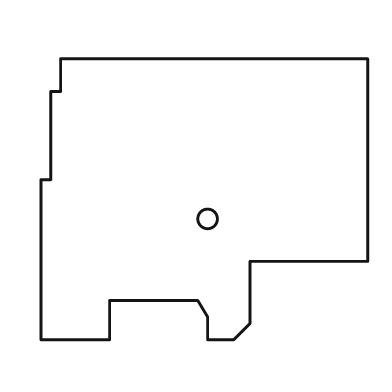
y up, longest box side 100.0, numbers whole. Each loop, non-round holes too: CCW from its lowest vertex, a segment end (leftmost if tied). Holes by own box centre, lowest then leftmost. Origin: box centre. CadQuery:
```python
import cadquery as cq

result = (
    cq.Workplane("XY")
    .moveTo(-50.0, -43.0)
    .lineTo(-29.0, -43.0)
    .lineTo(-29.0, -31.0)
    .lineTo(-2.0, -31.0)
    .lineTo(1.0, -36.0)
    .lineTo(1.0, -43.0)
    .lineTo(9.0, -43.0)
    .lineTo(14.0, -38.0)
    .lineTo(14.0, -19.0)
    .lineTo(50.0, -19.0)
    .lineTo(50.0, 43.0)
    .lineTo(-44.0, 43.0)
    .lineTo(-44.0, 33.0)
    .lineTo(-47.0, 33.0)
    .lineTo(-47.0, 6.0)
    .lineTo(-50.0, 6.0)
    .close()
    .moveTo(1.0, -6.0)
    .circle(3.0)
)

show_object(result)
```